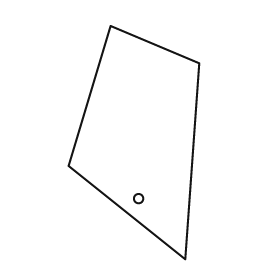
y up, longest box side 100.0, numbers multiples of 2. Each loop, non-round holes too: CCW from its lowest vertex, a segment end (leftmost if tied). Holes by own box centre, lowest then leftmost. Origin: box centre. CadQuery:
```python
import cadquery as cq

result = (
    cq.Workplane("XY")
    .moveTo(22.0, -50.0)
    .lineTo(28.0, 34.0)
    .lineTo(-10.0, 50.0)
    .lineTo(-28.0, -10.0)
    .close()
    .moveTo(2.0, -24.0)
    .circle(2.0)
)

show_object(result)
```